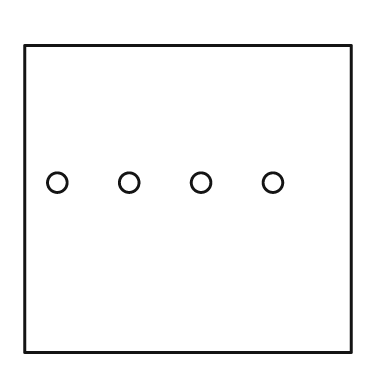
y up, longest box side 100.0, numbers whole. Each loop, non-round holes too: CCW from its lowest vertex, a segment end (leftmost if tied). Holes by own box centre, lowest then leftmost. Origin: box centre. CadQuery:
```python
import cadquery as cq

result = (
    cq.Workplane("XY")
    .moveTo(-50.0, -47.0)
    .lineTo(50.0, -47.0)
    .lineTo(50.0, 47.0)
    .lineTo(-50.0, 47.0)
    .close()
    .moveTo(-40.0, 5.0)
    .circle(3.0)
    .moveTo(-18.0, 5.0)
    .circle(3.0)
    .moveTo(4.0, 5.0)
    .circle(3.0)
    .moveTo(26.0, 5.0)
    .circle(3.0)
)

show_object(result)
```